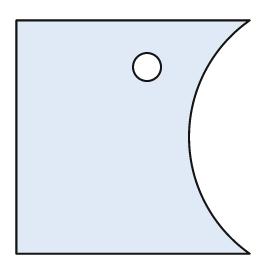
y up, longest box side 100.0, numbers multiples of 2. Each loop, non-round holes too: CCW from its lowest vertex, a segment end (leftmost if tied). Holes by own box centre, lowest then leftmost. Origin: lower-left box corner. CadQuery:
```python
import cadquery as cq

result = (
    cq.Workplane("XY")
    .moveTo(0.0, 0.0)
    .lineTo(100.0, 0.0)
    .threePointArc((74.0, 50.0), (100.0, 100.0))
    .lineTo(0.0, 100.0)
    .close()
    .moveTo(56.0, 80.0)
    .circle(6.0)
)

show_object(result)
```